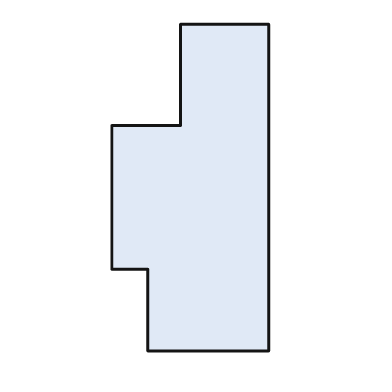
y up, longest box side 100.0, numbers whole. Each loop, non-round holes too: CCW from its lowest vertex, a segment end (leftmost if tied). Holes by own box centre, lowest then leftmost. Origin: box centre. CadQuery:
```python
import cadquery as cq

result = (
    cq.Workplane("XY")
    .moveTo(-13.0, -50.0)
    .lineTo(24.0, -50.0)
    .lineTo(24.0, 50.0)
    .lineTo(-3.0, 50.0)
    .lineTo(-3.0, 19.0)
    .lineTo(-24.0, 19.0)
    .lineTo(-24.0, -25.0)
    .lineTo(-13.0, -25.0)
    .close()
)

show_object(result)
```